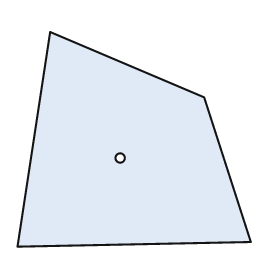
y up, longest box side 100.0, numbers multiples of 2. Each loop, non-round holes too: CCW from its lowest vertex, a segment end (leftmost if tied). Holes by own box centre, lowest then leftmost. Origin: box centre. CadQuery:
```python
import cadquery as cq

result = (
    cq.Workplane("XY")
    .moveTo(-50.0, -46.0)
    .lineTo(50.0, -44.0)
    .lineTo(30.0, 18.0)
    .lineTo(-36.0, 46.0)
    .close()
    .moveTo(-6.0, -8.0)
    .circle(2.0)
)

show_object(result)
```